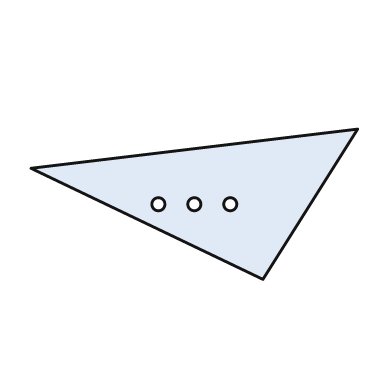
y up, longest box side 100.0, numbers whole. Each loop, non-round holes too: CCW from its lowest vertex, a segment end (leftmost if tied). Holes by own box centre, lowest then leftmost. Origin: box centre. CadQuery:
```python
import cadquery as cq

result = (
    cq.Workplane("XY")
    .moveTo(21.0, -23.0)
    .lineTo(50.0, 23.0)
    .lineTo(-50.0, 11.0)
    .close()
    .moveTo(-11.0, 0.0)
    .circle(2.0)
    .moveTo(0.0, 0.0)
    .circle(2.0)
    .moveTo(11.0, 0.0)
    .circle(2.0)
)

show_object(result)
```